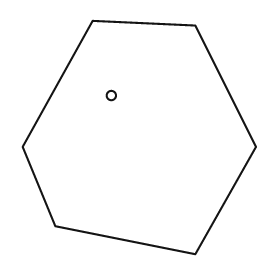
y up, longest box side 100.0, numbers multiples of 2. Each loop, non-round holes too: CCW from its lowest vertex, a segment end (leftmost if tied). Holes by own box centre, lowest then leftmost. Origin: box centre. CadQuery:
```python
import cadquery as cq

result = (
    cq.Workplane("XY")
    .moveTo(24.0, -50.0)
    .lineTo(50.0, -4.0)
    .lineTo(24.0, 48.0)
    .lineTo(-20.0, 50.0)
    .lineTo(-50.0, -4.0)
    .lineTo(-36.0, -38.0)
    .close()
    .moveTo(-12.0, 18.0)
    .circle(2.0)
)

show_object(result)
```